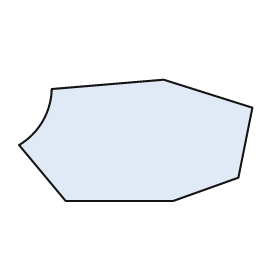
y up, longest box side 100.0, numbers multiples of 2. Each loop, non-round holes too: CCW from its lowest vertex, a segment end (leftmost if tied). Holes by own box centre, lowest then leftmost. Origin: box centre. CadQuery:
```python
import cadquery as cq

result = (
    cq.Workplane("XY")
    .moveTo(-30.0, -26.0)
    .lineTo(16.0, -26.0)
    .lineTo(44.0, -16.0)
    .lineTo(50.0, 14.0)
    .lineTo(12.0, 26.0)
    .lineTo(-36.0, 22.0)
    .threePointArc((-40.0, 8.0), (-50.0, -2.0))
    .close()
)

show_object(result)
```